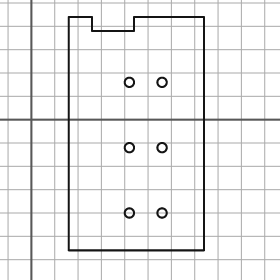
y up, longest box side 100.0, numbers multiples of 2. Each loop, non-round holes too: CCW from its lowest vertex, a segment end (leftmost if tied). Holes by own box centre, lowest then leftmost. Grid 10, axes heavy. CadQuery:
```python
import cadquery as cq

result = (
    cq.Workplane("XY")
    .moveTo(16.0, -56.0)
    .lineTo(74.0, -56.0)
    .lineTo(74.0, 44.0)
    .lineTo(44.0, 44.0)
    .lineTo(44.0, 38.0)
    .lineTo(26.0, 38.0)
    .lineTo(26.0, 44.0)
    .lineTo(16.0, 44.0)
    .close()
    .moveTo(42.0, -40.0)
    .circle(2.0)
    .moveTo(56.0, -40.0)
    .circle(2.0)
    .moveTo(42.0, -12.0)
    .circle(2.0)
    .moveTo(56.0, -12.0)
    .circle(2.0)
    .moveTo(42.0, 16.0)
    .circle(2.0)
    .moveTo(56.0, 16.0)
    .circle(2.0)
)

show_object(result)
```